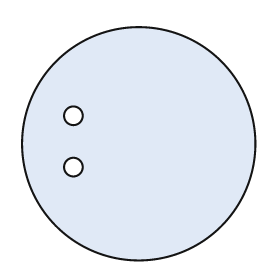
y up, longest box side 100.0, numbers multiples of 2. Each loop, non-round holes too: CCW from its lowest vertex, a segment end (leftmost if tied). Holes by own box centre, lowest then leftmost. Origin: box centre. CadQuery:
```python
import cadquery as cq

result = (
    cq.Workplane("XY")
    .moveTo(0.0, 0.0)
    .circle(50.0)
    .moveTo(-28.0, -10.0)
    .circle(4.0)
    .moveTo(-28.0, 12.0)
    .circle(4.0)
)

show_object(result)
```